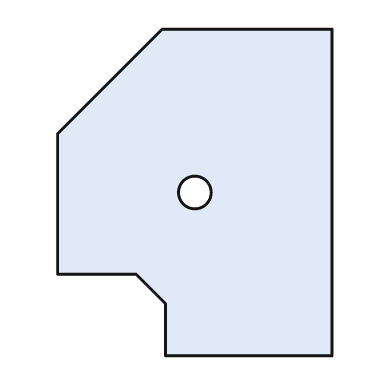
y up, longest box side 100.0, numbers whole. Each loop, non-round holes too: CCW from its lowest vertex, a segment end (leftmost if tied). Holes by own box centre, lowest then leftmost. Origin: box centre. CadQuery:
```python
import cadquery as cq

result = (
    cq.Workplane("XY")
    .moveTo(-9.0, -50.0)
    .lineTo(42.0, -50.0)
    .lineTo(42.0, 50.0)
    .lineTo(-10.0, 50.0)
    .lineTo(-42.0, 18.0)
    .lineTo(-42.0, -25.0)
    .lineTo(-18.0, -25.0)
    .lineTo(-9.0, -34.0)
    .close()
    .moveTo(0.0, 0.0)
    .circle(5.0)
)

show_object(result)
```